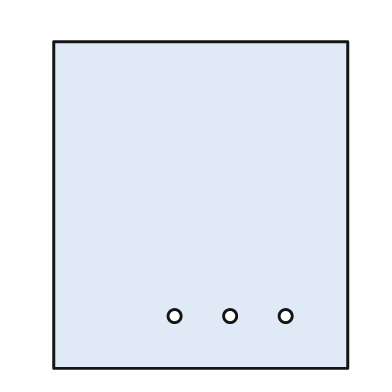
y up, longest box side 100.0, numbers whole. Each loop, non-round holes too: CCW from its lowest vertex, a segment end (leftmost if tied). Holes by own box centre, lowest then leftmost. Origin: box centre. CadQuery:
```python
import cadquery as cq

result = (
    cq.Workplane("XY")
    .moveTo(-45.0, -50.0)
    .lineTo(45.0, -50.0)
    .lineTo(45.0, 50.0)
    .lineTo(-45.0, 50.0)
    .close()
    .moveTo(-8.0, -34.0)
    .circle(2.0)
    .moveTo(9.0, -34.0)
    .circle(2.0)
    .moveTo(26.0, -34.0)
    .circle(2.0)
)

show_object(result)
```